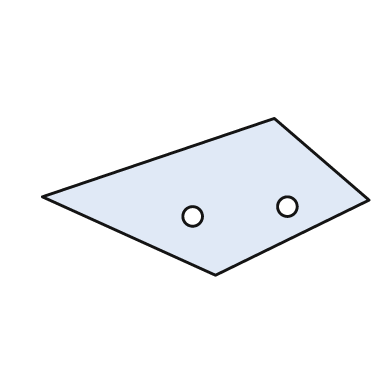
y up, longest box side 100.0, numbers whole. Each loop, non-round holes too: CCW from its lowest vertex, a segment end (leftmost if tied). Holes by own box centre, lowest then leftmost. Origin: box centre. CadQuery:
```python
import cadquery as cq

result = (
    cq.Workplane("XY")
    .moveTo(3.0, -24.0)
    .lineTo(50.0, -1.0)
    .lineTo(21.0, 24.0)
    .lineTo(-50.0, 0.0)
    .close()
    .moveTo(-4.0, -6.0)
    .circle(3.0)
    .moveTo(25.0, -3.0)
    .circle(3.0)
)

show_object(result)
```